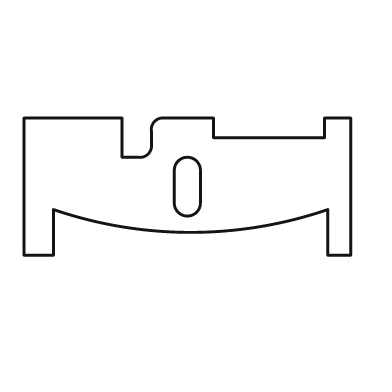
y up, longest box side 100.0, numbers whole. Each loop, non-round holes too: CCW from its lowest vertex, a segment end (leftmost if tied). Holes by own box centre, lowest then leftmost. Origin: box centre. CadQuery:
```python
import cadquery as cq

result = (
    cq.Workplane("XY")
    .moveTo(-50.0, -21.0)
    .lineTo(-41.0, -21.0)
    .lineTo(-41.0, -7.0)
    .threePointArc((1.0, -14.0), (43.0, -7.0))
    .lineTo(43.0, -21.0)
    .lineTo(50.0, -21.0)
    .lineTo(50.0, 21.0)
    .lineTo(42.0, 21.0)
    .lineTo(42.0, 15.0)
    .lineTo(8.0, 15.0)
    .lineTo(8.0, 21.0)
    .lineTo(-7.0, 21.0)
    .threePointArc((-10.0, 20.0), (-11.0, 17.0))
    .lineTo(-11.0, 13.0)
    .threePointArc((-12.0, 10.0), (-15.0, 9.0))
    .lineTo(-20.0, 9.0)
    .lineTo(-20.0, 21.0)
    .lineTo(-50.0, 21.0)
    .close()
    .moveTo(-4.0, -5.0)
    .threePointArc((0.0, -9.0), (4.0, -5.0))
    .lineTo(4.0, 5.0)
    .threePointArc((0.0, 9.0), (-4.0, 5.0))
    .close()
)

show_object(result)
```